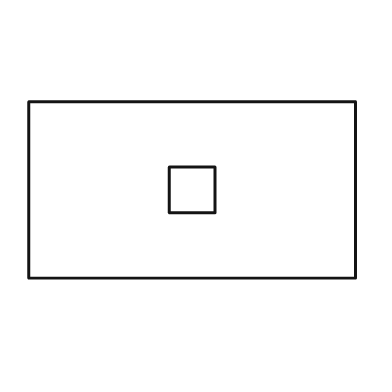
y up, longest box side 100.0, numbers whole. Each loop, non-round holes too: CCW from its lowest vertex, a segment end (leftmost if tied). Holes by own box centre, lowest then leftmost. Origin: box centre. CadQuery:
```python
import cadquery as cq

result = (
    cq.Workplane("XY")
    .moveTo(-50.0, -27.0)
    .lineTo(50.0, -27.0)
    .lineTo(50.0, 27.0)
    .lineTo(-50.0, 27.0)
    .close()
    .moveTo(-7.0, -7.0)
    .lineTo(7.0, -7.0)
    .lineTo(7.0, 7.0)
    .lineTo(-7.0, 7.0)
    .close()
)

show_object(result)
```